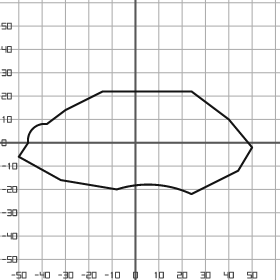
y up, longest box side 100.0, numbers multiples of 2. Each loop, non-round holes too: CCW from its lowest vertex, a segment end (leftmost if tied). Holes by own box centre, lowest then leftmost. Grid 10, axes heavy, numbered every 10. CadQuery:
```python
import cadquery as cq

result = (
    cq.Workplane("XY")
    .moveTo(24.0, -22.0)
    .lineTo(44.0, -12.0)
    .lineTo(50.0, -2.0)
    .lineTo(40.0, 10.0)
    .lineTo(24.0, 22.0)
    .lineTo(-14.0, 22.0)
    .lineTo(-30.0, 14.0)
    .lineTo(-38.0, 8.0)
    .threePointArc((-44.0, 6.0), (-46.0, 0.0))
    .lineTo(-50.0, -6.0)
    .lineTo(-32.0, -16.0)
    .lineTo(-8.0, -20.0)
    .threePointArc((8.0, -18.0), (24.0, -22.0))
    .close()
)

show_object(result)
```